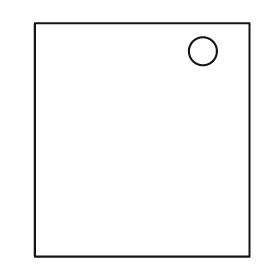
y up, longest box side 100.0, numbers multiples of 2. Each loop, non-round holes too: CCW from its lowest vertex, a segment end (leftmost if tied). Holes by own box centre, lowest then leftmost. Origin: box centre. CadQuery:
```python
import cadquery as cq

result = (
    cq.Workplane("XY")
    .moveTo(-46.0, -50.0)
    .lineTo(46.0, -50.0)
    .lineTo(46.0, 50.0)
    .lineTo(-46.0, 50.0)
    .close()
    .moveTo(26.0, 38.0)
    .circle(6.0)
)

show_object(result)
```